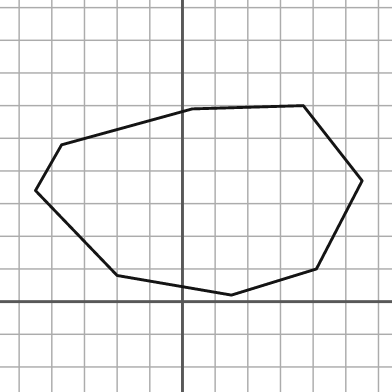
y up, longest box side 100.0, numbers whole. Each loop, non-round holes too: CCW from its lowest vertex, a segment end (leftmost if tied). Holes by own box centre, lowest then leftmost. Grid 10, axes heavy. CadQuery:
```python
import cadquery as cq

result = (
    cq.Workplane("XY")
    .moveTo(15.0, 2.0)
    .lineTo(41.0, 10.0)
    .lineTo(55.0, 37.0)
    .lineTo(37.0, 60.0)
    .lineTo(3.0, 59.0)
    .lineTo(-37.0, 48.0)
    .lineTo(-45.0, 34.0)
    .lineTo(-20.0, 8.0)
    .close()
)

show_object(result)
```